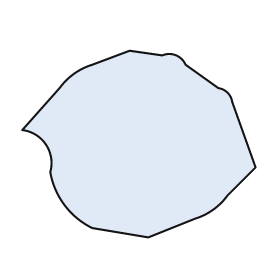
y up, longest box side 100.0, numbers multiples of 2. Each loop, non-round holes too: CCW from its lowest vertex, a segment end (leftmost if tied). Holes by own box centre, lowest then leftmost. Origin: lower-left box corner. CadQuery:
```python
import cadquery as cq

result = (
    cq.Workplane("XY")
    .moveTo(54.0, 0.0)
    .lineTo(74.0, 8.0)
    .threePointArc((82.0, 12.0), (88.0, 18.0))
    .lineTo(100.0, 30.0)
    .lineTo(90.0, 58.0)
    .threePointArc((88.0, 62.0), (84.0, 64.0))
    .lineTo(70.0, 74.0)
    .threePointArc((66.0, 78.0), (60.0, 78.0))
    .lineTo(46.0, 80.0)
    .lineTo(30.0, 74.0)
    .threePointArc((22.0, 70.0), (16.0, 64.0))
    .lineTo(0.0, 46.0)
    .threePointArc((10.0, 40.0), (12.0, 28.0))
    .threePointArc((18.0, 14.0), (30.0, 4.0))
    .close()
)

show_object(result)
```